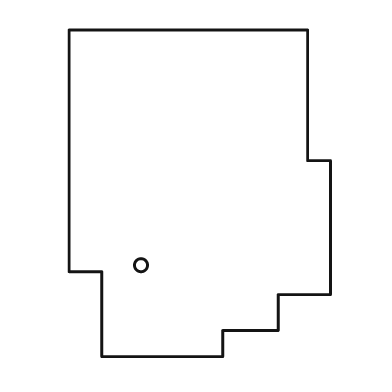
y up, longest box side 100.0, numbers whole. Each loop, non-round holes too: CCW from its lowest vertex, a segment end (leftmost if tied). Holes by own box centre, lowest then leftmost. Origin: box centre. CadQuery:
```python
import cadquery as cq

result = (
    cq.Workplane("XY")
    .moveTo(-30.0, -50.0)
    .lineTo(7.0, -50.0)
    .lineTo(7.0, -42.0)
    .lineTo(24.0, -42.0)
    .lineTo(24.0, -31.0)
    .lineTo(40.0, -31.0)
    .lineTo(40.0, 10.0)
    .lineTo(33.0, 10.0)
    .lineTo(33.0, 50.0)
    .lineTo(-40.0, 50.0)
    .lineTo(-40.0, -24.0)
    .lineTo(-30.0, -24.0)
    .close()
    .moveTo(-18.0, -22.0)
    .circle(2.0)
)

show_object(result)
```